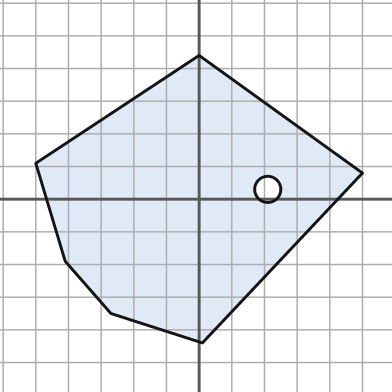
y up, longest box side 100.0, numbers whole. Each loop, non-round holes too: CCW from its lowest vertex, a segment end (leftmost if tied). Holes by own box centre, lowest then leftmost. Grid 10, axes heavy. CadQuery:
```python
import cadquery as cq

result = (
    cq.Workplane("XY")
    .moveTo(1.0, -44.0)
    .lineTo(50.0, 8.0)
    .lineTo(0.0, 44.0)
    .lineTo(-50.0, 11.0)
    .lineTo(-41.0, -19.0)
    .lineTo(-27.0, -35.0)
    .close()
    .moveTo(21.0, 3.0)
    .circle(4.0)
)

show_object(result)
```